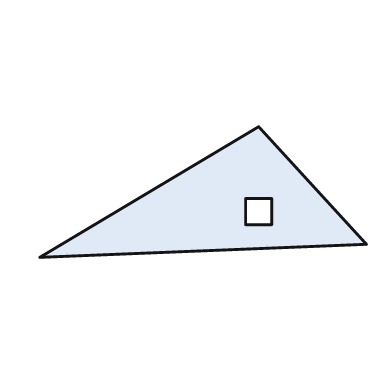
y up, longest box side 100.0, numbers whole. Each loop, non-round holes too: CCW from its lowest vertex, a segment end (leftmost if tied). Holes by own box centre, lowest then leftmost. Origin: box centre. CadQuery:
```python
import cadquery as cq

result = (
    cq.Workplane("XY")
    .moveTo(-50.0, -20.0)
    .lineTo(50.0, -16.0)
    .lineTo(17.0, 20.0)
    .close()
    .moveTo(13.0, -10.0)
    .lineTo(21.0, -10.0)
    .lineTo(21.0, -2.0)
    .lineTo(13.0, -2.0)
    .close()
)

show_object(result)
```